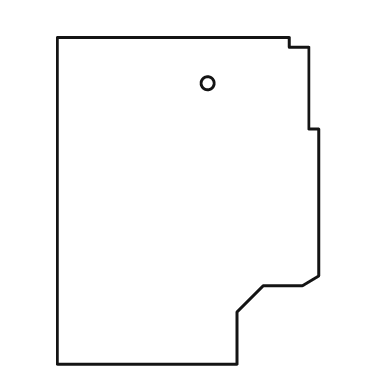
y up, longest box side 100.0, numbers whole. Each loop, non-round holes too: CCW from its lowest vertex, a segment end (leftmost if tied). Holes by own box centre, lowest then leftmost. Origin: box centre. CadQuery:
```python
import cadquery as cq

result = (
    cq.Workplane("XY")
    .moveTo(-40.0, -50.0)
    .lineTo(15.0, -50.0)
    .lineTo(15.0, -34.0)
    .lineTo(23.0, -26.0)
    .lineTo(35.0, -26.0)
    .lineTo(40.0, -23.0)
    .lineTo(40.0, 22.0)
    .lineTo(37.0, 22.0)
    .lineTo(37.0, 47.0)
    .lineTo(31.0, 47.0)
    .lineTo(31.0, 50.0)
    .lineTo(-40.0, 50.0)
    .close()
    .moveTo(6.0, 36.0)
    .circle(2.0)
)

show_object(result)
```